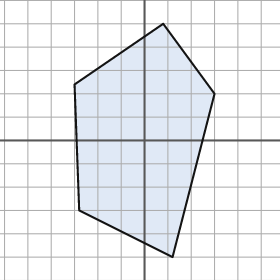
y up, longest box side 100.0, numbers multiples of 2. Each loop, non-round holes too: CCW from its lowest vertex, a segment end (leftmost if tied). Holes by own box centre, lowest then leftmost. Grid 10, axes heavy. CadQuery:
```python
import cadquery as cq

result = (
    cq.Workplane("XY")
    .moveTo(12.0, -50.0)
    .lineTo(30.0, 20.0)
    .lineTo(8.0, 50.0)
    .lineTo(-30.0, 24.0)
    .lineTo(-28.0, -30.0)
    .close()
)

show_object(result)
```